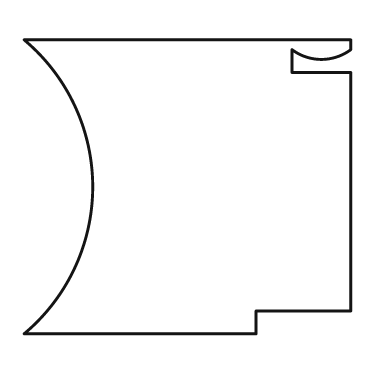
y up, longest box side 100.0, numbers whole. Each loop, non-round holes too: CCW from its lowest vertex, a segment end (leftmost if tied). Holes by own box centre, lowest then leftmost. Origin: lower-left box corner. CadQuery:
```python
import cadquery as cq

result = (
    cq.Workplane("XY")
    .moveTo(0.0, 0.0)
    .lineTo(71.0, 0.0)
    .lineTo(71.0, 7.0)
    .lineTo(100.0, 7.0)
    .lineTo(100.0, 80.0)
    .lineTo(82.0, 80.0)
    .lineTo(82.0, 87.0)
    .threePointArc((91.0, 84.0), (100.0, 87.0))
    .lineTo(100.0, 90.0)
    .lineTo(0.0, 90.0)
    .threePointArc((21.0, 45.0), (0.0, 0.0))
    .close()
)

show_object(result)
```